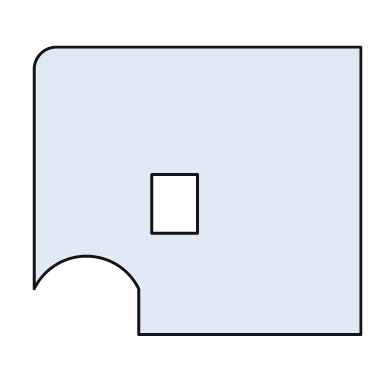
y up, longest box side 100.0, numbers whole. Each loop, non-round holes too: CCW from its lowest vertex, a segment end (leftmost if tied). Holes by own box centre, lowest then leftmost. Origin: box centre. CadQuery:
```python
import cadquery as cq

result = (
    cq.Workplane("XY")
    .moveTo(-18.0, -44.0)
    .lineTo(50.0, -44.0)
    .lineTo(50.0, 44.0)
    .lineTo(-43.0, 44.0)
    .threePointArc((-48.0, 42.0), (-50.0, 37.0))
    .lineTo(-50.0, -30.0)
    .threePointArc((-34.0, -20.0), (-18.0, -30.0))
    .close()
    .moveTo(-14.0, -13.0)
    .lineTo(0.0, -13.0)
    .lineTo(0.0, 5.0)
    .lineTo(-14.0, 5.0)
    .close()
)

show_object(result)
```